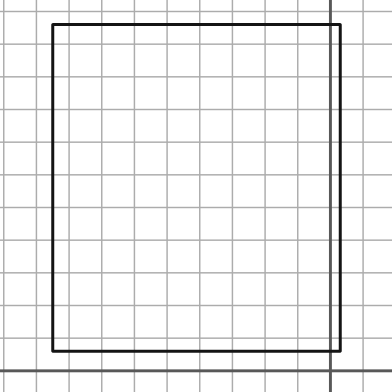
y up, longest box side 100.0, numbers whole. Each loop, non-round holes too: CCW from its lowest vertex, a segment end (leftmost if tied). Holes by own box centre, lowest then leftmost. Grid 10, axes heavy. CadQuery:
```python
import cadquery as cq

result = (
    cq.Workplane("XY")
    .moveTo(-85.0, 6.0)
    .lineTo(3.0, 6.0)
    .lineTo(3.0, 106.0)
    .lineTo(-85.0, 106.0)
    .close()
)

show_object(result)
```